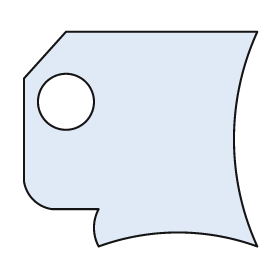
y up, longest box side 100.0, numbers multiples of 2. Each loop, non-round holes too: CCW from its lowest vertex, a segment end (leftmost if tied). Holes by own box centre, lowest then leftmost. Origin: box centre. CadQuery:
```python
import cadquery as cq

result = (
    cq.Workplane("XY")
    .moveTo(-18.0, -46.0)
    .threePointArc((16.0, -40.0), (50.0, -46.0))
    .threePointArc((40.0, 0.0), (50.0, 46.0))
    .lineTo(-32.0, 46.0)
    .lineTo(-50.0, 26.0)
    .lineTo(-50.0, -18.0)
    .threePointArc((-46.0, -26.0), (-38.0, -30.0))
    .lineTo(-18.0, -30.0)
    .threePointArc((-20.0, -38.0), (-18.0, -46.0))
    .close()
    .moveTo(-32.0, 16.0)
    .circle(12.0)
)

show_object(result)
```